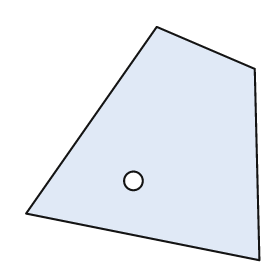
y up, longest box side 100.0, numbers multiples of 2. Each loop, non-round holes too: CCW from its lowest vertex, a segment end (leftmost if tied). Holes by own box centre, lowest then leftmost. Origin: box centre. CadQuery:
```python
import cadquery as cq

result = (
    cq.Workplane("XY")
    .moveTo(50.0, -50.0)
    .lineTo(48.0, 32.0)
    .lineTo(6.0, 50.0)
    .lineTo(-50.0, -30.0)
    .close()
    .moveTo(-4.0, -16.0)
    .circle(4.0)
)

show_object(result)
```